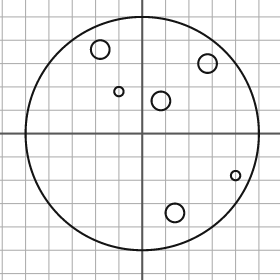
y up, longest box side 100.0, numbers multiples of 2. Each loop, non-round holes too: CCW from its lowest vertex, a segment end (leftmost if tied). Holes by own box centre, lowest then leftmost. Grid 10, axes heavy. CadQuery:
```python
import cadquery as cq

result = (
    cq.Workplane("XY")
    .moveTo(0.0, 0.0)
    .circle(50.0)
    .moveTo(14.0, -34.0)
    .circle(4.0)
    .moveTo(40.0, -18.0)
    .circle(2.0)
    .moveTo(8.0, 14.0)
    .circle(4.0)
    .moveTo(-10.0, 18.0)
    .circle(2.0)
    .moveTo(28.0, 30.0)
    .circle(4.0)
    .moveTo(-18.0, 36.0)
    .circle(4.0)
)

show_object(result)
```